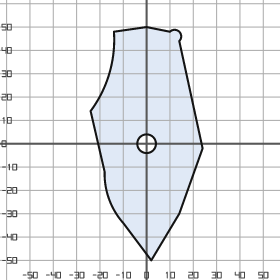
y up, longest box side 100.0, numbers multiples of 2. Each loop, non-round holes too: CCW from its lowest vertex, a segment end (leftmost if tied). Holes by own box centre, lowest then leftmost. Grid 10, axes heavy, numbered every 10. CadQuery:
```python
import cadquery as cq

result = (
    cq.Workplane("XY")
    .moveTo(2.0, -50.0)
    .lineTo(14.0, -30.0)
    .lineTo(24.0, -2.0)
    .lineTo(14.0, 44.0)
    .threePointArc((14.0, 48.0), (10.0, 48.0))
    .lineTo(0.0, 50.0)
    .lineTo(-14.0, 48.0)
    .threePointArc((-16.0, 30.0), (-24.0, 14.0))
    .lineTo(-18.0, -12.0)
    .threePointArc((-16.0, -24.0), (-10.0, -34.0))
    .close()
    .moveTo(0.0, 0.0)
    .circle(4.0)
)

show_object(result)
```